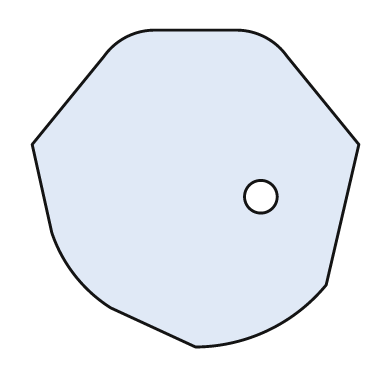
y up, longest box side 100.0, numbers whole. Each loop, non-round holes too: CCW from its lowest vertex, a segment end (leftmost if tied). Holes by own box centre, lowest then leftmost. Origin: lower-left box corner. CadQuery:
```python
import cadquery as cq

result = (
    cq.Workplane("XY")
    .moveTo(50.0, 0.0)
    .threePointArc((72.0, 5.0), (90.0, 19.0))
    .lineTo(100.0, 62.0)
    .lineTo(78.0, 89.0)
    .threePointArc((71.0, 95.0), (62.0, 97.0))
    .lineTo(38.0, 97.0)
    .threePointArc((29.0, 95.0), (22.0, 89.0))
    .lineTo(0.0, 62.0)
    .lineTo(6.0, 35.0)
    .threePointArc((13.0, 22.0), (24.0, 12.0))
    .close()
    .moveTo(70.0, 46.0)
    .circle(5.0)
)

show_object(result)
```